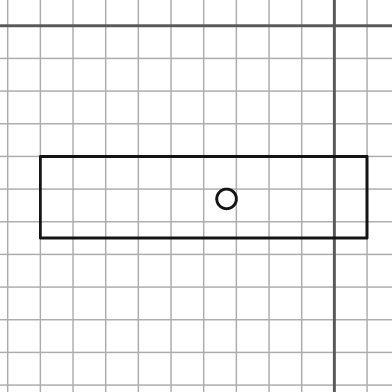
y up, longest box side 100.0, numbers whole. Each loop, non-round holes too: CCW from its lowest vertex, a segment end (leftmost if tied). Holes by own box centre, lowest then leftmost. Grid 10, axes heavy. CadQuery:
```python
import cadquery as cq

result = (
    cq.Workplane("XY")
    .moveTo(-90.0, -65.0)
    .lineTo(10.0, -65.0)
    .lineTo(10.0, -40.0)
    .lineTo(-90.0, -40.0)
    .close()
    .moveTo(-33.0, -53.0)
    .circle(3.0)
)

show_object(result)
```